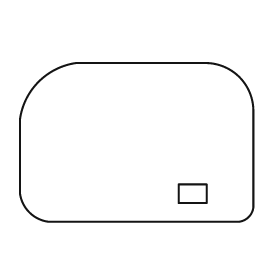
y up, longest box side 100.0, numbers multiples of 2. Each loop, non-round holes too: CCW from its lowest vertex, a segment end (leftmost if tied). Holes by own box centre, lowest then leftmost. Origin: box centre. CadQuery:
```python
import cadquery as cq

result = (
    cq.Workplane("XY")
    .moveTo(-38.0, -34.0)
    .lineTo(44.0, -34.0)
    .threePointArc((48.0, -32.0), (50.0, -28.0))
    .lineTo(50.0, 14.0)
    .threePointArc((44.0, 28.0), (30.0, 34.0))
    .lineTo(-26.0, 34.0)
    .threePointArc((-42.0, 26.0), (-50.0, 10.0))
    .lineTo(-50.0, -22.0)
    .threePointArc((-46.0, -30.0), (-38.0, -34.0))
    .close()
    .moveTo(18.0, -26.0)
    .lineTo(30.0, -26.0)
    .lineTo(30.0, -18.0)
    .lineTo(18.0, -18.0)
    .close()
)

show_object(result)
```